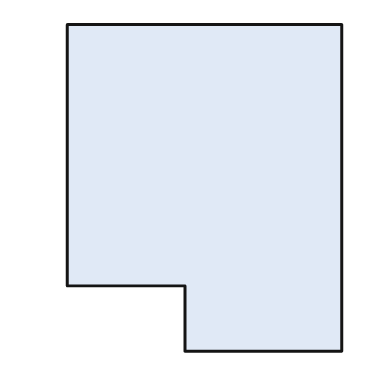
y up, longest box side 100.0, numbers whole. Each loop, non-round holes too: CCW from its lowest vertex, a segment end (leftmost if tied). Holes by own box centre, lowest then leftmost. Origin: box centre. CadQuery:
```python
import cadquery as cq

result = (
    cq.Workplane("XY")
    .moveTo(-6.0, -50.0)
    .lineTo(42.0, -50.0)
    .lineTo(42.0, 50.0)
    .lineTo(-42.0, 50.0)
    .lineTo(-42.0, -30.0)
    .lineTo(-6.0, -30.0)
    .close()
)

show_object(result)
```